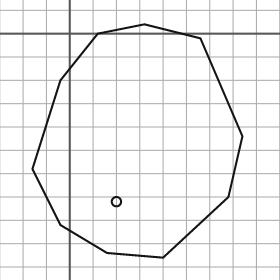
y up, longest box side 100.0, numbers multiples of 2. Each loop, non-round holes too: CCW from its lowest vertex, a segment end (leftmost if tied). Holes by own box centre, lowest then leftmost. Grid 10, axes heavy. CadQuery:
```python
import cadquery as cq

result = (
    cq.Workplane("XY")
    .moveTo(40.0, -96.0)
    .lineTo(68.0, -70.0)
    .lineTo(74.0, -44.0)
    .lineTo(56.0, -2.0)
    .lineTo(32.0, 4.0)
    .lineTo(12.0, 0.0)
    .lineTo(-4.0, -20.0)
    .lineTo(-16.0, -58.0)
    .lineTo(-4.0, -82.0)
    .lineTo(16.0, -94.0)
    .close()
    .moveTo(20.0, -72.0)
    .circle(2.0)
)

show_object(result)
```